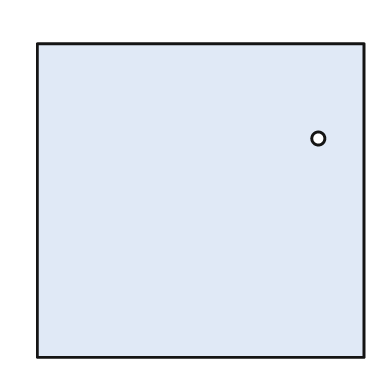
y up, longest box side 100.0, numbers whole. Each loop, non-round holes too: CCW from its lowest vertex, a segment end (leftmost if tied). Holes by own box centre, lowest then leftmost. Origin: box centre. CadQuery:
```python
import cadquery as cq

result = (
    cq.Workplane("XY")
    .moveTo(-50.0, -48.0)
    .lineTo(50.0, -48.0)
    .lineTo(50.0, 48.0)
    .lineTo(-50.0, 48.0)
    .close()
    .moveTo(36.0, 19.0)
    .circle(2.0)
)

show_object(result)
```